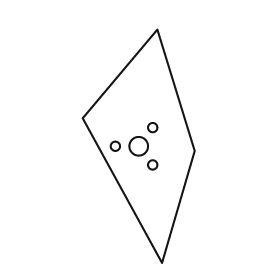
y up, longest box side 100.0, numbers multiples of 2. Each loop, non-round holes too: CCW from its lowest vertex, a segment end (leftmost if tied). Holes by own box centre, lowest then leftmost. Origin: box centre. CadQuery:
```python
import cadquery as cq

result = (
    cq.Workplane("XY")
    .moveTo(10.0, -50.0)
    .lineTo(24.0, -2.0)
    .lineTo(8.0, 50.0)
    .lineTo(-24.0, 12.0)
    .close()
    .moveTo(6.0, -8.0)
    .circle(2.0)
    .moveTo(-10.0, 0.0)
    .circle(2.0)
    .moveTo(0.0, 0.0)
    .circle(4.0)
    .moveTo(6.0, 8.0)
    .circle(2.0)
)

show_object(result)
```